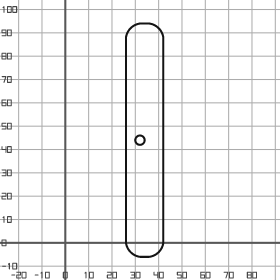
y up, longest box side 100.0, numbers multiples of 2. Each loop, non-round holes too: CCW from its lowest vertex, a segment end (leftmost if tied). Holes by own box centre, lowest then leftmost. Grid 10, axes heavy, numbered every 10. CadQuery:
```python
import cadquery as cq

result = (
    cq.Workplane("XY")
    .moveTo(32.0, -6.0)
    .lineTo(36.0, -6.0)
    .threePointArc((40.0, -4.0), (42.0, 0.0))
    .lineTo(42.0, 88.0)
    .threePointArc((40.0, 92.0), (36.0, 94.0))
    .lineTo(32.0, 94.0)
    .threePointArc((28.0, 92.0), (26.0, 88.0))
    .lineTo(26.0, 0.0)
    .threePointArc((28.0, -4.0), (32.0, -6.0))
    .close()
    .moveTo(32.0, 44.0)
    .circle(2.0)
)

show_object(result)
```